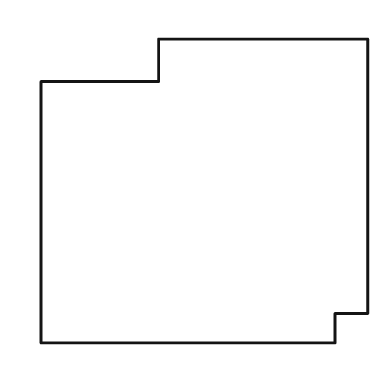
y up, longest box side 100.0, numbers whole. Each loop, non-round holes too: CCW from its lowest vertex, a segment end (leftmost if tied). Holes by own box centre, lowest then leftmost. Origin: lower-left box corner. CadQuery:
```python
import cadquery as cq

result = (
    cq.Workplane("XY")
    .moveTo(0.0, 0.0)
    .lineTo(90.0, 0.0)
    .lineTo(90.0, 9.0)
    .lineTo(100.0, 9.0)
    .lineTo(100.0, 93.0)
    .lineTo(36.0, 93.0)
    .lineTo(36.0, 80.0)
    .lineTo(0.0, 80.0)
    .close()
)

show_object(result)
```